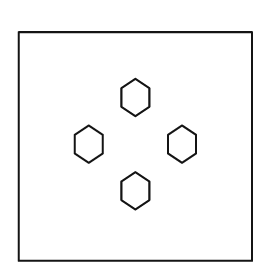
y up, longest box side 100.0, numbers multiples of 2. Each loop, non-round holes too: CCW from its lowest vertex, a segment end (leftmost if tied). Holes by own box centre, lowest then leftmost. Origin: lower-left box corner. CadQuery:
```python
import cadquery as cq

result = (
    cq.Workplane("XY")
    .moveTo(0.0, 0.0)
    .lineTo(100.0, 0.0)
    .lineTo(100.0, 98.0)
    .lineTo(0.0, 98.0)
    .close()
    .moveTo(50.0, 22.0)
    .lineTo(56.0, 26.0)
    .lineTo(56.0, 34.0)
    .lineTo(50.0, 38.0)
    .lineTo(44.0, 34.0)
    .lineTo(44.0, 26.0)
    .close()
    .moveTo(30.0, 42.0)
    .lineTo(36.0, 46.0)
    .lineTo(36.0, 54.0)
    .lineTo(30.0, 58.0)
    .lineTo(24.0, 54.0)
    .lineTo(24.0, 46.0)
    .close()
    .moveTo(70.0, 42.0)
    .lineTo(76.0, 46.0)
    .lineTo(76.0, 54.0)
    .lineTo(70.0, 58.0)
    .lineTo(64.0, 54.0)
    .lineTo(64.0, 46.0)
    .close()
    .moveTo(50.0, 62.0)
    .lineTo(56.0, 66.0)
    .lineTo(56.0, 74.0)
    .lineTo(50.0, 78.0)
    .lineTo(44.0, 74.0)
    .lineTo(44.0, 66.0)
    .close()
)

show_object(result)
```